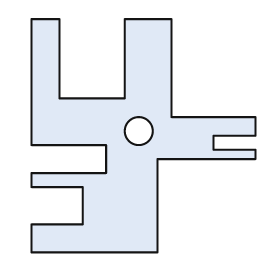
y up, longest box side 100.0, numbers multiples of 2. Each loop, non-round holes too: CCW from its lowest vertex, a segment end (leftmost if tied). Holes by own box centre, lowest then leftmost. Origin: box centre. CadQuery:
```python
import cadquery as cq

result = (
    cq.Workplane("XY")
    .moveTo(-48.0, -50.0)
    .lineTo(6.0, -50.0)
    .lineTo(6.0, -10.0)
    .lineTo(48.0, -10.0)
    .lineTo(48.0, -6.0)
    .lineTo(30.0, -6.0)
    .lineTo(30.0, 0.0)
    .lineTo(48.0, 0.0)
    .lineTo(48.0, 8.0)
    .lineTo(12.0, 8.0)
    .lineTo(12.0, 50.0)
    .lineTo(-8.0, 50.0)
    .lineTo(-8.0, 16.0)
    .lineTo(-36.0, 16.0)
    .lineTo(-36.0, 50.0)
    .lineTo(-48.0, 50.0)
    .lineTo(-48.0, -4.0)
    .lineTo(-16.0, -4.0)
    .lineTo(-16.0, -16.0)
    .lineTo(-48.0, -16.0)
    .lineTo(-48.0, -22.0)
    .lineTo(-26.0, -22.0)
    .lineTo(-26.0, -38.0)
    .lineTo(-48.0, -38.0)
    .close()
    .moveTo(-2.0, 2.0)
    .circle(6.0)
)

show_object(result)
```